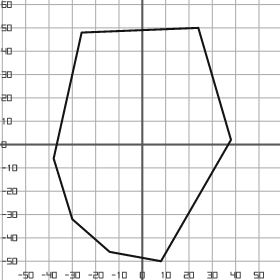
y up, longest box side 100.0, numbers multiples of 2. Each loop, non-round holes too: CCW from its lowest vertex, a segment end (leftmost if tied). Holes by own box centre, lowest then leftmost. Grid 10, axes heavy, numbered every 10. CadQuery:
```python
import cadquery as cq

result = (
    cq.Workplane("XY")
    .moveTo(8.0, -50.0)
    .lineTo(38.0, 2.0)
    .lineTo(24.0, 50.0)
    .lineTo(-26.0, 48.0)
    .lineTo(-38.0, -6.0)
    .lineTo(-30.0, -32.0)
    .lineTo(-14.0, -46.0)
    .close()
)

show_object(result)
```